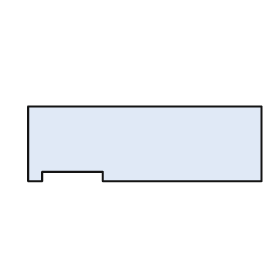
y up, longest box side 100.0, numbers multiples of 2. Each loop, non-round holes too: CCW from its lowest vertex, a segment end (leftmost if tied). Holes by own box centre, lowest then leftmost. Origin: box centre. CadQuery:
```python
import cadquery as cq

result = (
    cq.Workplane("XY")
    .moveTo(-50.0, -16.0)
    .lineTo(-44.0, -16.0)
    .lineTo(-44.0, -12.0)
    .lineTo(-18.0, -12.0)
    .lineTo(-18.0, -16.0)
    .lineTo(50.0, -16.0)
    .lineTo(50.0, 16.0)
    .lineTo(-50.0, 16.0)
    .close()
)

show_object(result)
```